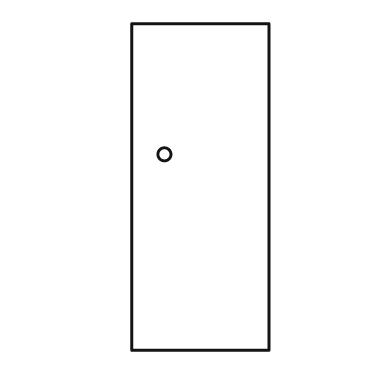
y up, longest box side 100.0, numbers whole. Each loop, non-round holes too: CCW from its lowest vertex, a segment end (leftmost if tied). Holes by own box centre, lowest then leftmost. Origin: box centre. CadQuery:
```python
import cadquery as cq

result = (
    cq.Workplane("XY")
    .moveTo(-21.0, -50.0)
    .lineTo(21.0, -50.0)
    .lineTo(21.0, 50.0)
    .lineTo(-21.0, 50.0)
    .close()
    .moveTo(-11.0, 10.0)
    .circle(2.0)
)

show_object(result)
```